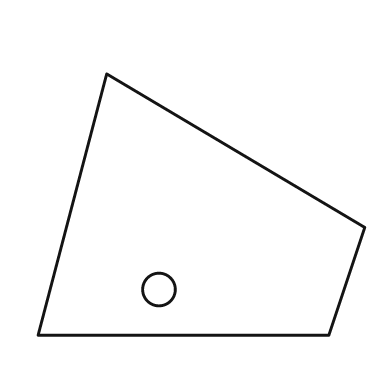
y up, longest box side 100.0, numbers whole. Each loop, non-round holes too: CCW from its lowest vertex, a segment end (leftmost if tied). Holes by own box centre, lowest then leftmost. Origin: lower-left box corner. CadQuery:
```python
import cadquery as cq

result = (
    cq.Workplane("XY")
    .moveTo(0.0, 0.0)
    .lineTo(89.0, 0.0)
    .lineTo(100.0, 33.0)
    .lineTo(21.0, 80.0)
    .close()
    .moveTo(37.0, 14.0)
    .circle(5.0)
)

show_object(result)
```